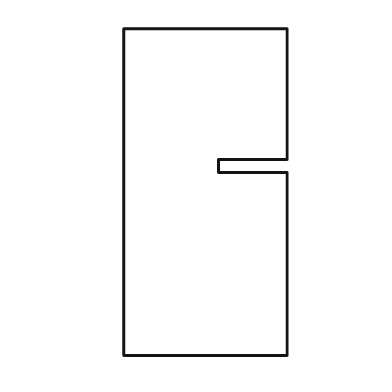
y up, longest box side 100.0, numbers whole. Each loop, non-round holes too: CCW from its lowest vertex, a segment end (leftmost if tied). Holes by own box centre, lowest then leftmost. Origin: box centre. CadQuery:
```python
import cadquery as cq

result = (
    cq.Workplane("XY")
    .moveTo(-25.0, -50.0)
    .lineTo(25.0, -50.0)
    .lineTo(25.0, 6.0)
    .lineTo(4.0, 6.0)
    .lineTo(4.0, 10.0)
    .lineTo(25.0, 10.0)
    .lineTo(25.0, 50.0)
    .lineTo(-25.0, 50.0)
    .close()
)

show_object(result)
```